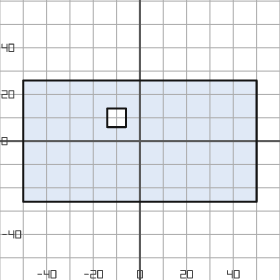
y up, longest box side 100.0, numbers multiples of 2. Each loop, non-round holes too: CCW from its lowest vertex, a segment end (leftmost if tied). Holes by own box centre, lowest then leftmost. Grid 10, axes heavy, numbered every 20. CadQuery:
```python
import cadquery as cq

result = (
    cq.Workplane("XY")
    .moveTo(-50.0, -26.0)
    .lineTo(50.0, -26.0)
    .lineTo(50.0, 26.0)
    .lineTo(-50.0, 26.0)
    .close()
    .moveTo(-14.0, 6.0)
    .lineTo(-6.0, 6.0)
    .lineTo(-6.0, 14.0)
    .lineTo(-14.0, 14.0)
    .close()
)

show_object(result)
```